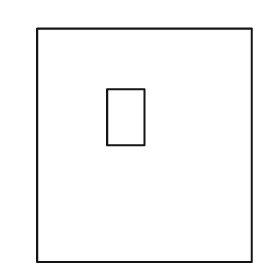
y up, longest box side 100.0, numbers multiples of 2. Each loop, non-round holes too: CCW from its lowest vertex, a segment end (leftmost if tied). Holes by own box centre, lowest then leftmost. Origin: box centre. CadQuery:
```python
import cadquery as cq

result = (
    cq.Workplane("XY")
    .moveTo(-46.0, -50.0)
    .lineTo(46.0, -50.0)
    .lineTo(46.0, 50.0)
    .lineTo(-46.0, 50.0)
    .close()
    .moveTo(-16.0, 0.0)
    .lineTo(0.0, 0.0)
    .lineTo(0.0, 24.0)
    .lineTo(-16.0, 24.0)
    .close()
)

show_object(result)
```